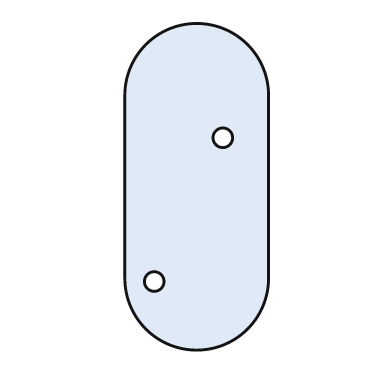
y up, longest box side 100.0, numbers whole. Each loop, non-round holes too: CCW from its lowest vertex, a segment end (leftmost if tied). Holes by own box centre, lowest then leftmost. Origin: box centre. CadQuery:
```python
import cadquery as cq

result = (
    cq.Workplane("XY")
    .moveTo(-22.0, -28.0)
    .threePointArc((0.0, -50.0), (22.0, -28.0))
    .lineTo(22.0, 28.0)
    .threePointArc((0.0, 50.0), (-22.0, 28.0))
    .close()
    .moveTo(-13.0, -29.0)
    .circle(3.0)
    .moveTo(8.0, 15.0)
    .circle(3.0)
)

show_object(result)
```